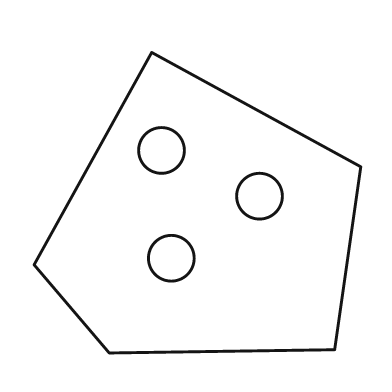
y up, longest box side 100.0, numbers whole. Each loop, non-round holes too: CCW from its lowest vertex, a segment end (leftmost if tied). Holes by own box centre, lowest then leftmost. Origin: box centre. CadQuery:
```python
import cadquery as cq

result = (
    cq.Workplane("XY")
    .moveTo(-27.0, -46.0)
    .lineTo(42.0, -45.0)
    .lineTo(50.0, 11.0)
    .lineTo(-14.0, 46.0)
    .lineTo(-50.0, -19.0)
    .close()
    .moveTo(-8.0, -17.0)
    .circle(7.0)
    .moveTo(19.0, 2.0)
    .circle(7.0)
    .moveTo(-11.0, 16.0)
    .circle(7.0)
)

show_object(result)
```